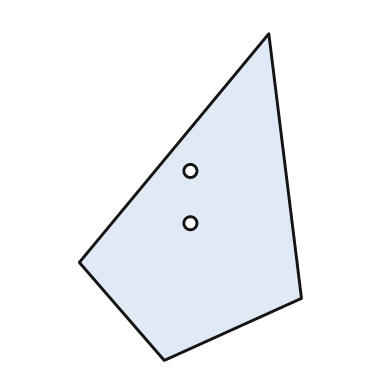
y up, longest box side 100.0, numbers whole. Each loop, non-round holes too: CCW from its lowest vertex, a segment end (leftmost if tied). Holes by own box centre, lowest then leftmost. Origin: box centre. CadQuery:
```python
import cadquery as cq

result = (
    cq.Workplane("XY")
    .moveTo(-8.0, -50.0)
    .lineTo(34.0, -31.0)
    .lineTo(24.0, 50.0)
    .lineTo(-34.0, -20.0)
    .close()
    .moveTo(0.0, -8.0)
    .circle(2.0)
    .moveTo(0.0, 8.0)
    .circle(2.0)
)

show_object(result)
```